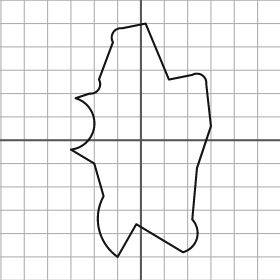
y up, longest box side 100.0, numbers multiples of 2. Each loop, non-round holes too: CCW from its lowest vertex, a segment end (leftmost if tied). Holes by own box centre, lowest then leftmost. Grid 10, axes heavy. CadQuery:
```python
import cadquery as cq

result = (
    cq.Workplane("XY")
    .moveTo(-10.0, -50.0)
    .lineTo(-2.0, -36.0)
    .lineTo(18.0, -48.0)
    .threePointArc((24.0, -42.0), (22.0, -34.0))
    .lineTo(24.0, -12.0)
    .lineTo(30.0, 6.0)
    .lineTo(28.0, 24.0)
    .threePointArc((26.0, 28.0), (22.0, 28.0))
    .lineTo(12.0, 26.0)
    .lineTo(2.0, 50.0)
    .lineTo(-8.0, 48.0)
    .threePointArc((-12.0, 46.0), (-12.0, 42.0))
    .lineTo(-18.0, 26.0)
    .threePointArc((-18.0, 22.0), (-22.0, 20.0))
    .lineTo(-28.0, 18.0)
    .threePointArc((-20.0, 6.0), (-30.0, -4.0))
    .lineTo(-20.0, -10.0)
    .lineTo(-16.0, -24.0)
    .threePointArc((-18.0, -38.0), (-10.0, -50.0))
    .close()
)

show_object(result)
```